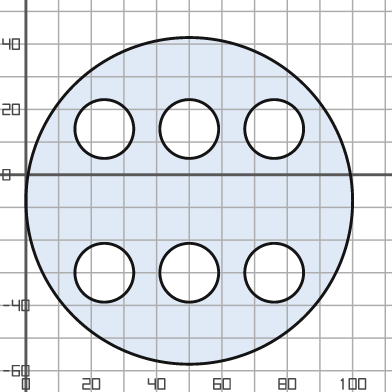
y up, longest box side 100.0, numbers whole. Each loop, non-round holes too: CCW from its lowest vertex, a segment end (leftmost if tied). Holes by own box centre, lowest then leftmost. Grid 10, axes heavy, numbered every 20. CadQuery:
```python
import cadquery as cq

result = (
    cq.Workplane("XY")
    .moveTo(50.0, -8.0)
    .circle(50.0)
    .moveTo(24.0, -30.0)
    .circle(9.0)
    .moveTo(50.0, -30.0)
    .circle(9.0)
    .moveTo(76.0, -30.0)
    .circle(9.0)
    .moveTo(24.0, 14.0)
    .circle(9.0)
    .moveTo(50.0, 14.0)
    .circle(9.0)
    .moveTo(76.0, 14.0)
    .circle(9.0)
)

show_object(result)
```